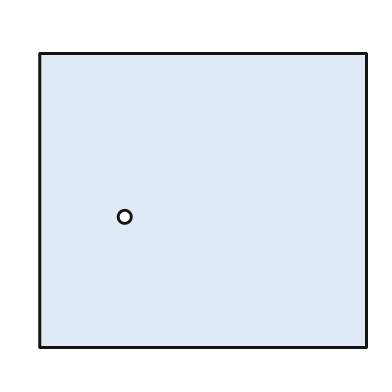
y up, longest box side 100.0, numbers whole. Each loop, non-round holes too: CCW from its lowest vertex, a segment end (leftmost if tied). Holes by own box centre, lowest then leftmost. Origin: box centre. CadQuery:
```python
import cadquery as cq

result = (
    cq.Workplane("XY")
    .moveTo(-50.0, -45.0)
    .lineTo(50.0, -45.0)
    .lineTo(50.0, 45.0)
    .lineTo(-50.0, 45.0)
    .close()
    .moveTo(-24.0, -5.0)
    .circle(2.0)
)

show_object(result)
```